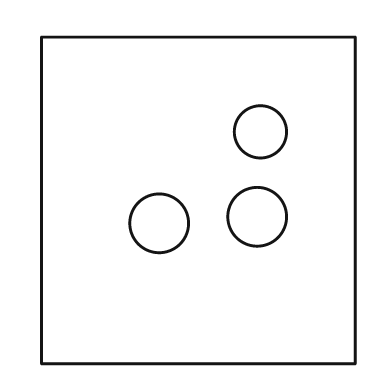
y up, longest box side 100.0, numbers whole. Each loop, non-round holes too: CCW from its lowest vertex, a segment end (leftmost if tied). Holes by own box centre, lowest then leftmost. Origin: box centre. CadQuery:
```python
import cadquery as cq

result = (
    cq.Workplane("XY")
    .moveTo(-48.0, -50.0)
    .lineTo(48.0, -50.0)
    .lineTo(48.0, 50.0)
    .lineTo(-48.0, 50.0)
    .close()
    .moveTo(-12.0, -7.0)
    .circle(9.0)
    .moveTo(18.0, -5.0)
    .circle(9.0)
    .moveTo(19.0, 21.0)
    .circle(8.0)
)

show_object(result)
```